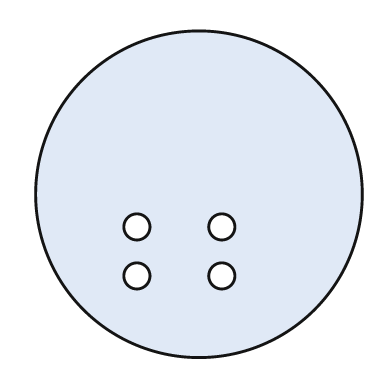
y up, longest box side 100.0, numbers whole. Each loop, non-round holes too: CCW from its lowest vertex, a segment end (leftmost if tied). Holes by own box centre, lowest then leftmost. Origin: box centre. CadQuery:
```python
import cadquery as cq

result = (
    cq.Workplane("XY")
    .moveTo(0.0, 0.0)
    .circle(50.0)
    .moveTo(-19.0, -25.0)
    .circle(4.0)
    .moveTo(7.0, -25.0)
    .circle(4.0)
    .moveTo(-19.0, -10.0)
    .circle(4.0)
    .moveTo(7.0, -10.0)
    .circle(4.0)
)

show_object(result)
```